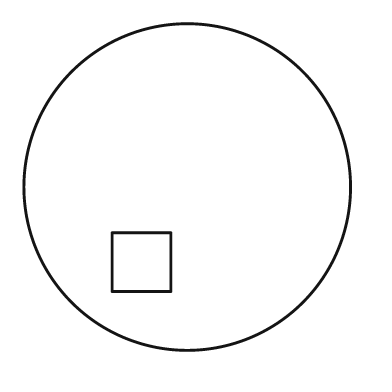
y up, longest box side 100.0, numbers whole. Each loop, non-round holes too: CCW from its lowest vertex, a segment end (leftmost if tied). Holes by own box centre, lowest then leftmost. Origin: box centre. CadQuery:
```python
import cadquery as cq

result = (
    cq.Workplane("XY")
    .moveTo(0.0, 0.0)
    .circle(50.0)
    .moveTo(-23.0, -32.0)
    .lineTo(-5.0, -32.0)
    .lineTo(-5.0, -14.0)
    .lineTo(-23.0, -14.0)
    .close()
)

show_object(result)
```